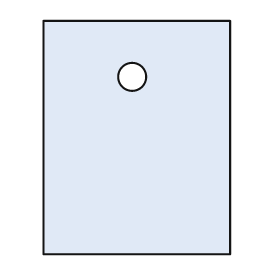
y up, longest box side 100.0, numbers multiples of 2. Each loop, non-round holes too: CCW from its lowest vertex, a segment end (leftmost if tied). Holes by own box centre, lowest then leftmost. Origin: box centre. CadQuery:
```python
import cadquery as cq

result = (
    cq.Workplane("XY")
    .moveTo(-40.0, -50.0)
    .lineTo(40.0, -50.0)
    .lineTo(40.0, 50.0)
    .lineTo(-40.0, 50.0)
    .close()
    .moveTo(-2.0, 26.0)
    .circle(6.0)
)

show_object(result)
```